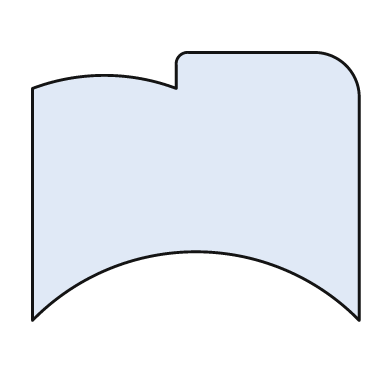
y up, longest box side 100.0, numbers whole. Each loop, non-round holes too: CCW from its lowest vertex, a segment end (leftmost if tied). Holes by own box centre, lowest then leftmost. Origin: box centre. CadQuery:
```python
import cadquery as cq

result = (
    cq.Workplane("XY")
    .moveTo(-50.0, -41.0)
    .threePointArc((0.0, -20.0), (50.0, -41.0))
    .lineTo(50.0, 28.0)
    .threePointArc((46.0, 37.0), (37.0, 41.0))
    .lineTo(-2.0, 41.0)
    .threePointArc((-5.0, 40.0), (-6.0, 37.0))
    .lineTo(-6.0, 30.0)
    .threePointArc((-28.0, 34.0), (-50.0, 30.0))
    .close()
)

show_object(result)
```